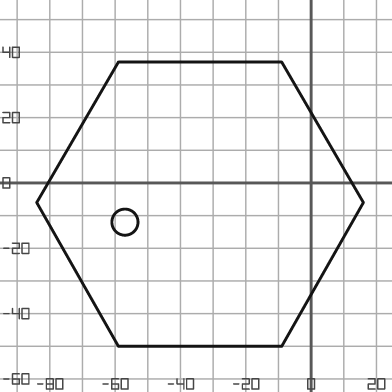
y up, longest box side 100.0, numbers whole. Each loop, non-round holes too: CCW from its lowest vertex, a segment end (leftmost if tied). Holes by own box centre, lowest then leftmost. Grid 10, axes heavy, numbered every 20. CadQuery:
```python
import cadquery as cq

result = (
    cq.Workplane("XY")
    .moveTo(-59.0, -50.0)
    .lineTo(-9.0, -50.0)
    .lineTo(16.0, -6.0)
    .lineTo(-9.0, 37.0)
    .lineTo(-59.0, 37.0)
    .lineTo(-84.0, -6.0)
    .close()
    .moveTo(-57.0, -12.0)
    .circle(4.0)
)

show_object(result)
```